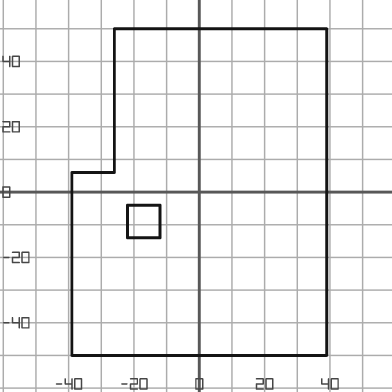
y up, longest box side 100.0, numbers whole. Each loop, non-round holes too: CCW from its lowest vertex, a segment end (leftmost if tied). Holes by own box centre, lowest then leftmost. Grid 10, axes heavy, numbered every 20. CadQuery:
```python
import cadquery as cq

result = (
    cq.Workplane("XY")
    .moveTo(-39.0, -50.0)
    .lineTo(39.0, -50.0)
    .lineTo(39.0, 50.0)
    .lineTo(-26.0, 50.0)
    .lineTo(-26.0, 6.0)
    .lineTo(-39.0, 6.0)
    .close()
    .moveTo(-22.0, -14.0)
    .lineTo(-12.0, -14.0)
    .lineTo(-12.0, -4.0)
    .lineTo(-22.0, -4.0)
    .close()
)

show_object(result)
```